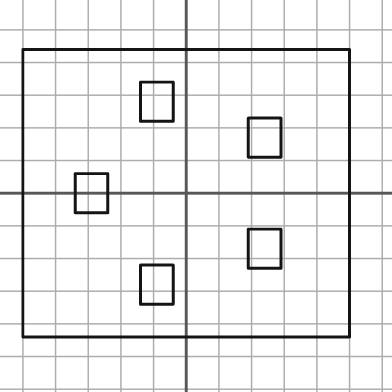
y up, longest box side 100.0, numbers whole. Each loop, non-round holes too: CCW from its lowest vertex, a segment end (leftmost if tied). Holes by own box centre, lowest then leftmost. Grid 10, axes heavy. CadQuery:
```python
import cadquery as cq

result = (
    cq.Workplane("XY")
    .moveTo(-50.0, -44.0)
    .lineTo(50.0, -44.0)
    .lineTo(50.0, 44.0)
    .lineTo(-50.0, 44.0)
    .close()
    .moveTo(-14.0, -34.0)
    .lineTo(-4.0, -34.0)
    .lineTo(-4.0, -22.0)
    .lineTo(-14.0, -22.0)
    .close()
    .moveTo(19.0, -23.0)
    .lineTo(29.0, -23.0)
    .lineTo(29.0, -11.0)
    .lineTo(19.0, -11.0)
    .close()
    .moveTo(-34.0, -6.0)
    .lineTo(-24.0, -6.0)
    .lineTo(-24.0, 6.0)
    .lineTo(-34.0, 6.0)
    .close()
    .moveTo(19.0, 11.0)
    .lineTo(29.0, 11.0)
    .lineTo(29.0, 23.0)
    .lineTo(19.0, 23.0)
    .close()
    .moveTo(-14.0, 22.0)
    .lineTo(-4.0, 22.0)
    .lineTo(-4.0, 34.0)
    .lineTo(-14.0, 34.0)
    .close()
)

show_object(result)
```